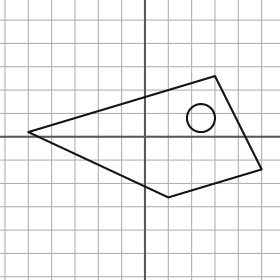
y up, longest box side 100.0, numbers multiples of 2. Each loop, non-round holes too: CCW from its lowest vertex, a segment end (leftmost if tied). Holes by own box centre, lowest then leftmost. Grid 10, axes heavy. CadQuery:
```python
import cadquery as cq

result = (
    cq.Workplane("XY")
    .moveTo(10.0, -26.0)
    .lineTo(50.0, -14.0)
    .lineTo(30.0, 26.0)
    .lineTo(-50.0, 2.0)
    .close()
    .moveTo(24.0, 8.0)
    .circle(6.0)
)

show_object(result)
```